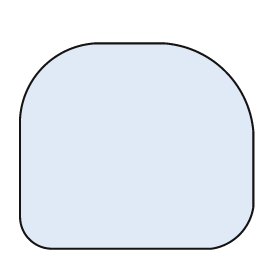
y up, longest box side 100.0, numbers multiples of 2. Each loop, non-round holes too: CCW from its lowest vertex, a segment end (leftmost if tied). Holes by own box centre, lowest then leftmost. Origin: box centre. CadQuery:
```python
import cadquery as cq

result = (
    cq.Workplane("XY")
    .moveTo(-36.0, -44.0)
    .lineTo(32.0, -44.0)
    .threePointArc((44.0, -38.0), (50.0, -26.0))
    .lineTo(50.0, 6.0)
    .threePointArc((38.0, 32.0), (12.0, 44.0))
    .lineTo(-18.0, 44.0)
    .threePointArc((-40.0, 34.0), (-50.0, 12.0))
    .lineTo(-50.0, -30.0)
    .threePointArc((-46.0, -40.0), (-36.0, -44.0))
    .close()
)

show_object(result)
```